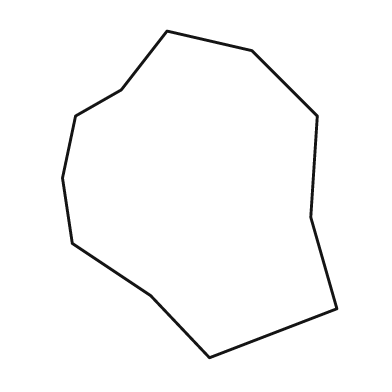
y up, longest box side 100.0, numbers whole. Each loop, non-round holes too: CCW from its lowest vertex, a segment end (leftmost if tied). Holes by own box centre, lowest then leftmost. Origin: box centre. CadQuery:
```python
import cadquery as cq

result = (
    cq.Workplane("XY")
    .moveTo(3.0, -50.0)
    .lineTo(42.0, -35.0)
    .lineTo(34.0, -7.0)
    .lineTo(36.0, 24.0)
    .lineTo(16.0, 44.0)
    .lineTo(-10.0, 50.0)
    .lineTo(-24.0, 32.0)
    .lineTo(-38.0, 24.0)
    .lineTo(-42.0, 5.0)
    .lineTo(-39.0, -15.0)
    .lineTo(-15.0, -31.0)
    .close()
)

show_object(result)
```